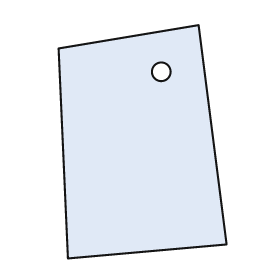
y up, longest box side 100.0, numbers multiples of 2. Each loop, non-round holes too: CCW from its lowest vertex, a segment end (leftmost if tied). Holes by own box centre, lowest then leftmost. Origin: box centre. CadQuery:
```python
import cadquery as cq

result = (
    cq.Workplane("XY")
    .moveTo(-32.0, -50.0)
    .lineTo(36.0, -44.0)
    .lineTo(24.0, 50.0)
    .lineTo(-36.0, 40.0)
    .close()
    .moveTo(8.0, 30.0)
    .circle(4.0)
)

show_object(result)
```